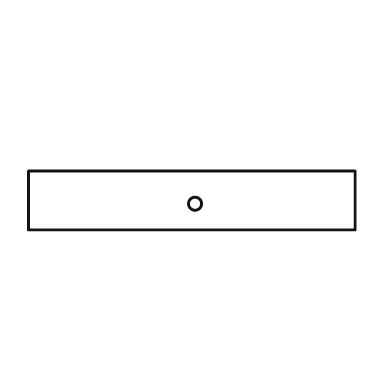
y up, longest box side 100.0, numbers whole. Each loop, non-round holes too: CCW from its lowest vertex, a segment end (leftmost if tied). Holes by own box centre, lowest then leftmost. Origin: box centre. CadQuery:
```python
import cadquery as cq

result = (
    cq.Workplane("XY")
    .moveTo(-50.0, -9.0)
    .lineTo(50.0, -9.0)
    .lineTo(50.0, 9.0)
    .lineTo(-50.0, 9.0)
    .close()
    .moveTo(1.0, -1.0)
    .circle(2.0)
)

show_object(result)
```